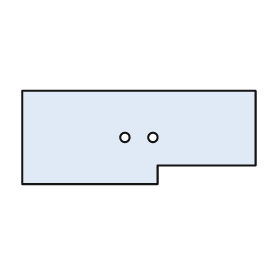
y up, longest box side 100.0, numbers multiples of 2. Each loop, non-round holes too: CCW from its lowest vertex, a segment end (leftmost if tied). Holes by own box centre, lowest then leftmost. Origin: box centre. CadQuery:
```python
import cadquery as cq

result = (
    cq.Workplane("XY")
    .moveTo(-50.0, -20.0)
    .lineTo(8.0, -20.0)
    .lineTo(8.0, -12.0)
    .lineTo(50.0, -12.0)
    .lineTo(50.0, 20.0)
    .lineTo(-50.0, 20.0)
    .close()
    .moveTo(-6.0, 0.0)
    .circle(2.0)
    .moveTo(6.0, 0.0)
    .circle(2.0)
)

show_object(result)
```